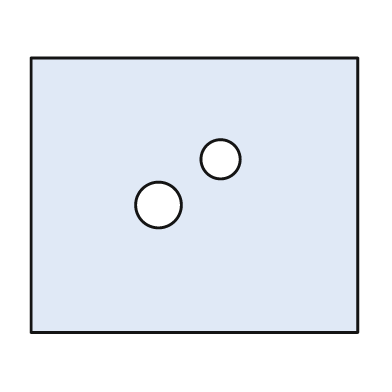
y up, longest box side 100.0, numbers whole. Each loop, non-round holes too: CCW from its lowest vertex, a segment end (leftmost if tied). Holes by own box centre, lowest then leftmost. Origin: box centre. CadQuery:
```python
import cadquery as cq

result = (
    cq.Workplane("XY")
    .moveTo(-50.0, -42.0)
    .lineTo(50.0, -42.0)
    .lineTo(50.0, 42.0)
    .lineTo(-50.0, 42.0)
    .close()
    .moveTo(-11.0, -3.0)
    .circle(7.0)
    .moveTo(8.0, 11.0)
    .circle(6.0)
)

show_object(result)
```